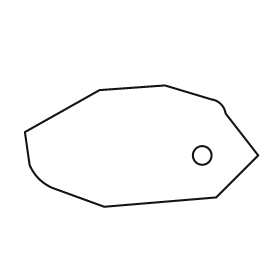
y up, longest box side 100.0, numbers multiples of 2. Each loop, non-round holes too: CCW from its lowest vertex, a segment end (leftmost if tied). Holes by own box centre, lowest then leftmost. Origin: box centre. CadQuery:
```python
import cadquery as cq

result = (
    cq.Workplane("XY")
    .moveTo(-16.0, -26.0)
    .lineTo(32.0, -22.0)
    .lineTo(50.0, -4.0)
    .lineTo(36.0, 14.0)
    .threePointArc((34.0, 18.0), (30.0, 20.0))
    .lineTo(10.0, 26.0)
    .lineTo(-18.0, 24.0)
    .lineTo(-50.0, 6.0)
    .lineTo(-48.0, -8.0)
    .threePointArc((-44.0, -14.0), (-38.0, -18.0))
    .close()
    .moveTo(26.0, -4.0)
    .circle(4.0)
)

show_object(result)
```